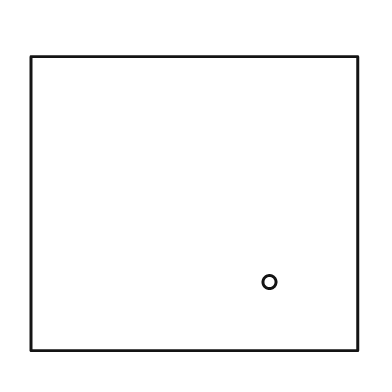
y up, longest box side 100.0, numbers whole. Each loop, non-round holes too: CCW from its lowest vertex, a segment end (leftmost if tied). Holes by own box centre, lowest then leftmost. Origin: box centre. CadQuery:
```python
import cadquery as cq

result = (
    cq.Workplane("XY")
    .moveTo(-50.0, -45.0)
    .lineTo(50.0, -45.0)
    .lineTo(50.0, 45.0)
    .lineTo(-50.0, 45.0)
    .close()
    .moveTo(23.0, -24.0)
    .circle(2.0)
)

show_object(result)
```